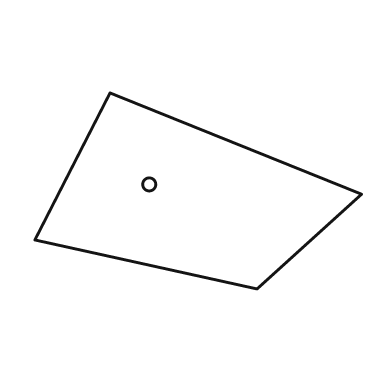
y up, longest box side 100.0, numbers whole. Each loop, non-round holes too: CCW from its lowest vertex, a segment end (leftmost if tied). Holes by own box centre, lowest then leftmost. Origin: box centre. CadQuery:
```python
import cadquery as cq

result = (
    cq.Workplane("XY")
    .moveTo(18.0, -30.0)
    .lineTo(50.0, -1.0)
    .lineTo(-27.0, 30.0)
    .lineTo(-50.0, -15.0)
    .close()
    .moveTo(-15.0, 2.0)
    .circle(2.0)
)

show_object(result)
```